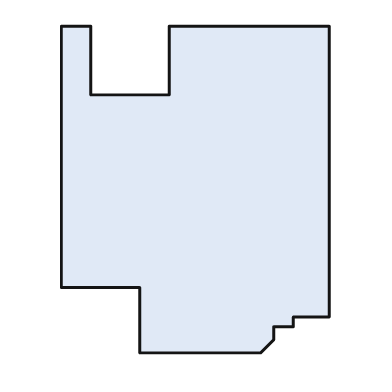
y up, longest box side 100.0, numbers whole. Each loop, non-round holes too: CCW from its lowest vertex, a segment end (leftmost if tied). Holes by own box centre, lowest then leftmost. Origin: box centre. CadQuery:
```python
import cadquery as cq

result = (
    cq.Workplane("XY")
    .moveTo(-17.0, -50.0)
    .lineTo(20.0, -50.0)
    .lineTo(24.0, -46.0)
    .lineTo(24.0, -42.0)
    .lineTo(30.0, -42.0)
    .lineTo(30.0, -39.0)
    .lineTo(41.0, -39.0)
    .lineTo(41.0, 50.0)
    .lineTo(-8.0, 50.0)
    .lineTo(-8.0, 29.0)
    .lineTo(-32.0, 29.0)
    .lineTo(-32.0, 50.0)
    .lineTo(-41.0, 50.0)
    .lineTo(-41.0, -30.0)
    .lineTo(-17.0, -30.0)
    .close()
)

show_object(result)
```